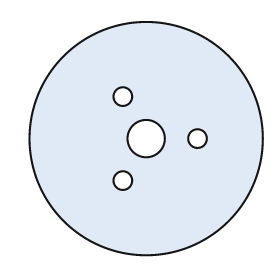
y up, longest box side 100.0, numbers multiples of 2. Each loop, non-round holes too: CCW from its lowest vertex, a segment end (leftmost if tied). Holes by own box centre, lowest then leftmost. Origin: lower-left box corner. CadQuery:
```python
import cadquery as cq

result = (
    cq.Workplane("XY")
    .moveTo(50.0, 50.0)
    .circle(50.0)
    .moveTo(40.0, 32.0)
    .circle(4.0)
    .moveTo(50.0, 50.0)
    .circle(8.0)
    .moveTo(72.0, 50.0)
    .circle(4.0)
    .moveTo(40.0, 68.0)
    .circle(4.0)
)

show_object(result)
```